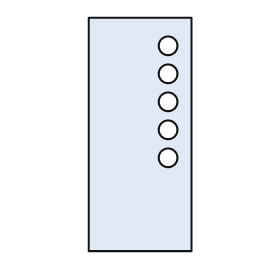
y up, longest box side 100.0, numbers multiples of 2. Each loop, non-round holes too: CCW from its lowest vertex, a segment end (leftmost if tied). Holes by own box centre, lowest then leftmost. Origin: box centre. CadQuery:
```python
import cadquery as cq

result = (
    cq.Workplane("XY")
    .moveTo(-22.0, -50.0)
    .lineTo(22.0, -50.0)
    .lineTo(22.0, 50.0)
    .lineTo(-22.0, 50.0)
    .close()
    .moveTo(12.0, -10.0)
    .circle(4.0)
    .moveTo(12.0, 2.0)
    .circle(4.0)
    .moveTo(12.0, 14.0)
    .circle(4.0)
    .moveTo(12.0, 26.0)
    .circle(4.0)
    .moveTo(12.0, 38.0)
    .circle(4.0)
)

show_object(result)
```